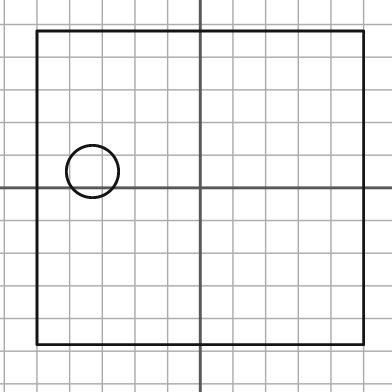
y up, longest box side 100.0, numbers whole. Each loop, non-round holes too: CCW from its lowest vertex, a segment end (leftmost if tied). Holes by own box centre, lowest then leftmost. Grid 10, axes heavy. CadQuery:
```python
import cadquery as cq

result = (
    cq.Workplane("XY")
    .moveTo(-50.0, -48.0)
    .lineTo(50.0, -48.0)
    .lineTo(50.0, 48.0)
    .lineTo(-50.0, 48.0)
    .close()
    .moveTo(-33.0, 5.0)
    .circle(8.0)
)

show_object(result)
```